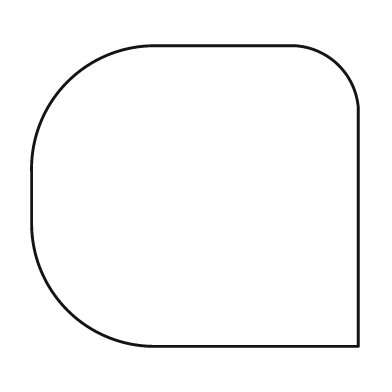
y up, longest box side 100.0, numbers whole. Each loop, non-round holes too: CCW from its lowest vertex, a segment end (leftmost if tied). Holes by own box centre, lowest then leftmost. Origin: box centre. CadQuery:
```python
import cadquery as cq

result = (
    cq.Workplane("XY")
    .moveTo(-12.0, -46.0)
    .lineTo(50.0, -46.0)
    .lineTo(50.0, 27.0)
    .threePointArc((44.0, 40.0), (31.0, 46.0))
    .lineTo(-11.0, 46.0)
    .threePointArc((-39.0, 35.0), (-50.0, 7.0))
    .lineTo(-50.0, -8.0)
    .threePointArc((-39.0, -35.0), (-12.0, -46.0))
    .close()
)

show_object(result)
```